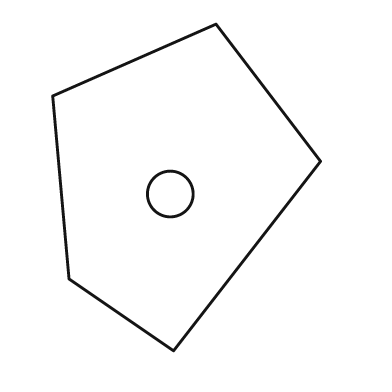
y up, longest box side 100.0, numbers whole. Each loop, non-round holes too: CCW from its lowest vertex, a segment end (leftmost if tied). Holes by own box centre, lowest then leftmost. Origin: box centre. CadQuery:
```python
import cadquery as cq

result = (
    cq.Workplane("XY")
    .moveTo(-4.0, -50.0)
    .lineTo(41.0, 8.0)
    .lineTo(9.0, 50.0)
    .lineTo(-41.0, 28.0)
    .lineTo(-36.0, -28.0)
    .close()
    .moveTo(-5.0, -2.0)
    .circle(7.0)
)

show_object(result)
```